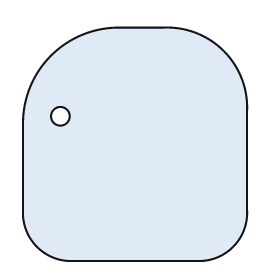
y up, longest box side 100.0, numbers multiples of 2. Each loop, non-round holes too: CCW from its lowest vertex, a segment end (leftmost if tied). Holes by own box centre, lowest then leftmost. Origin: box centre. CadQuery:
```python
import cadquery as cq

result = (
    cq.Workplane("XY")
    .moveTo(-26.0, -50.0)
    .lineTo(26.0, -50.0)
    .threePointArc((42.0, -44.0), (48.0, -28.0))
    .lineTo(48.0, 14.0)
    .threePointArc((38.0, 40.0), (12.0, 50.0))
    .lineTo(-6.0, 50.0)
    .threePointArc((-36.0, 38.0), (-48.0, 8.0))
    .lineTo(-48.0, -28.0)
    .threePointArc((-42.0, -44.0), (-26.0, -50.0))
    .close()
    .moveTo(-32.0, 12.0)
    .circle(4.0)
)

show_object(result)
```